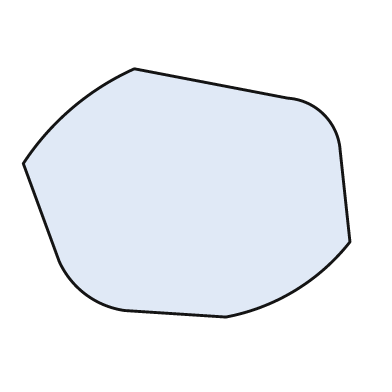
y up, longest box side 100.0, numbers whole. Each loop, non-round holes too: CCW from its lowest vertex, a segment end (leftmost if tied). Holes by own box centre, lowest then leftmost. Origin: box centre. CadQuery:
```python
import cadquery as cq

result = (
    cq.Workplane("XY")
    .moveTo(12.0, -38.0)
    .threePointArc((33.0, -30.0), (50.0, -15.0))
    .lineTo(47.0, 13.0)
    .threePointArc((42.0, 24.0), (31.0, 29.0))
    .lineTo(-16.0, 38.0)
    .threePointArc((-35.0, 26.0), (-50.0, 9.0))
    .lineTo(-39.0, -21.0)
    .threePointArc((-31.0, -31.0), (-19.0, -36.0))
    .close()
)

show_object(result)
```